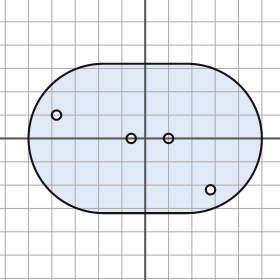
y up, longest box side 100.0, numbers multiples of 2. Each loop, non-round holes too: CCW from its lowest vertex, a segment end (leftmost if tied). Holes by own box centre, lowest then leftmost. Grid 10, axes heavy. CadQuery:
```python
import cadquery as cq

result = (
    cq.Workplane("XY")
    .moveTo(-18.0, -32.0)
    .lineTo(18.0, -32.0)
    .threePointArc((50.0, 0.0), (18.0, 32.0))
    .lineTo(-18.0, 32.0)
    .threePointArc((-50.0, 0.0), (-18.0, -32.0))
    .close()
    .moveTo(28.0, -22.0)
    .circle(2.0)
    .moveTo(-6.0, 0.0)
    .circle(2.0)
    .moveTo(10.0, 0.0)
    .circle(2.0)
    .moveTo(-38.0, 10.0)
    .circle(2.0)
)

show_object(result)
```